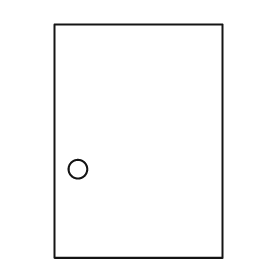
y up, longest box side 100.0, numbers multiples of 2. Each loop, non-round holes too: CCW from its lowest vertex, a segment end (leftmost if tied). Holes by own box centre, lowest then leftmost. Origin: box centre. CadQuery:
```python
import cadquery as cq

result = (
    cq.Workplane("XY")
    .moveTo(-36.0, -50.0)
    .lineTo(36.0, -50.0)
    .lineTo(36.0, 50.0)
    .lineTo(-36.0, 50.0)
    .close()
    .moveTo(-26.0, -12.0)
    .circle(4.0)
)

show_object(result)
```